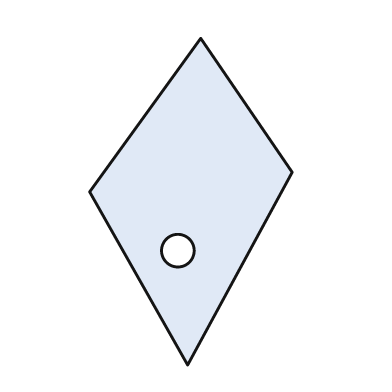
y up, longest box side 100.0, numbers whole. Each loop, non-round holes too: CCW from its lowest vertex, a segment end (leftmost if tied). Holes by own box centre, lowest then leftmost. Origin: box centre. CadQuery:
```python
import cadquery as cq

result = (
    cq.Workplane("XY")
    .moveTo(-1.0, -50.0)
    .lineTo(31.0, 9.0)
    .lineTo(3.0, 50.0)
    .lineTo(-31.0, 3.0)
    .close()
    .moveTo(-4.0, -15.0)
    .circle(5.0)
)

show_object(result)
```